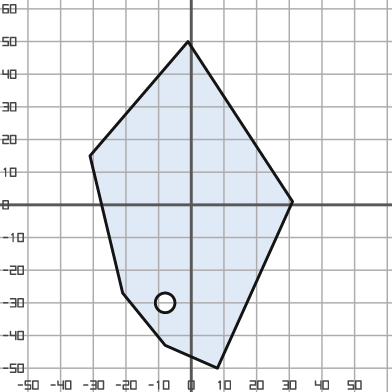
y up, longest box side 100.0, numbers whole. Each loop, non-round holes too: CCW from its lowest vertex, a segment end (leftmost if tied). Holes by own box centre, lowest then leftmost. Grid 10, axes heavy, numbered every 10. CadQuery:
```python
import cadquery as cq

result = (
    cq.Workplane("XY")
    .moveTo(8.0, -50.0)
    .lineTo(31.0, 1.0)
    .lineTo(-1.0, 50.0)
    .lineTo(-31.0, 15.0)
    .lineTo(-21.0, -27.0)
    .lineTo(-8.0, -43.0)
    .close()
    .moveTo(-8.0, -30.0)
    .circle(3.0)
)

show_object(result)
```